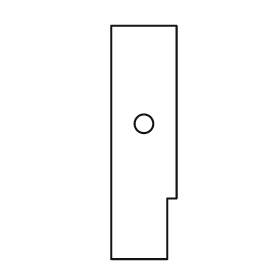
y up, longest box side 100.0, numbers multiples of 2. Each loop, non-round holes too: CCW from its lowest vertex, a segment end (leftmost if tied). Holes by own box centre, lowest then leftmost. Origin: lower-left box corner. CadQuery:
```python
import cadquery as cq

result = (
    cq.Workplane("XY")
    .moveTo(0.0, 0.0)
    .lineTo(24.0, 0.0)
    .lineTo(24.0, 26.0)
    .lineTo(28.0, 26.0)
    .lineTo(28.0, 100.0)
    .lineTo(0.0, 100.0)
    .close()
    .moveTo(14.0, 58.0)
    .circle(4.0)
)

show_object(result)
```